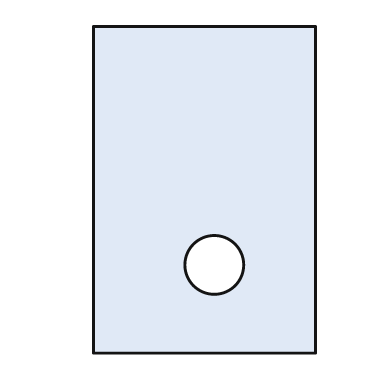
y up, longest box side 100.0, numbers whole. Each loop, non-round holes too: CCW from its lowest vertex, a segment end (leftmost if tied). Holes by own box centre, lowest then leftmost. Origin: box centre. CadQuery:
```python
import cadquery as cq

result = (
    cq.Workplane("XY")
    .moveTo(-34.0, -50.0)
    .lineTo(34.0, -50.0)
    .lineTo(34.0, 50.0)
    .lineTo(-34.0, 50.0)
    .close()
    .moveTo(3.0, -23.0)
    .circle(9.0)
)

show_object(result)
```